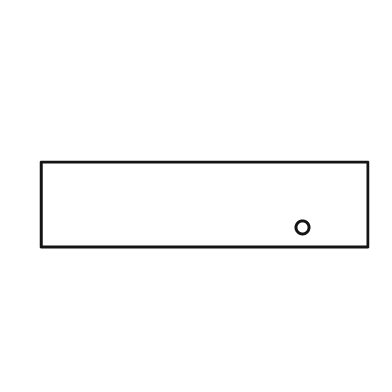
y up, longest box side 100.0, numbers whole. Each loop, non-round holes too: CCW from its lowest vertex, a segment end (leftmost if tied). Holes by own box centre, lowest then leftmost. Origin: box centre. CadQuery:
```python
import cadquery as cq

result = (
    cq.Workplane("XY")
    .moveTo(-50.0, -13.0)
    .lineTo(50.0, -13.0)
    .lineTo(50.0, 13.0)
    .lineTo(-50.0, 13.0)
    .close()
    .moveTo(30.0, -7.0)
    .circle(2.0)
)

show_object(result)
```